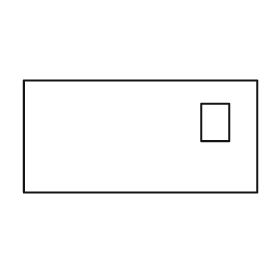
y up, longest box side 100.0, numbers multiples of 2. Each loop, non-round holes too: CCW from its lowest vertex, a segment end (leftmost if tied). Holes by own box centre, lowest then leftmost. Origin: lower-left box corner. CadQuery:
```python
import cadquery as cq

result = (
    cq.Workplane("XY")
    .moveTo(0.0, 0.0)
    .lineTo(100.0, 0.0)
    .lineTo(100.0, 48.0)
    .lineTo(0.0, 48.0)
    .close()
    .moveTo(76.0, 22.0)
    .lineTo(88.0, 22.0)
    .lineTo(88.0, 38.0)
    .lineTo(76.0, 38.0)
    .close()
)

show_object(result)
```